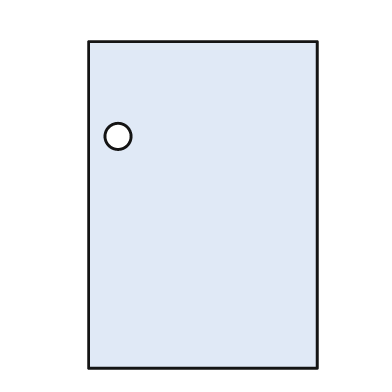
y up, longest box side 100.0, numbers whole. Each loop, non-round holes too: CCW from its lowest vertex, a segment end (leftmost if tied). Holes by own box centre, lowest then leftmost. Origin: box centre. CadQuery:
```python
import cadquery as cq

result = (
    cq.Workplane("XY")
    .moveTo(-35.0, -50.0)
    .lineTo(35.0, -50.0)
    .lineTo(35.0, 50.0)
    .lineTo(-35.0, 50.0)
    .close()
    .moveTo(-26.0, 21.0)
    .circle(4.0)
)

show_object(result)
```